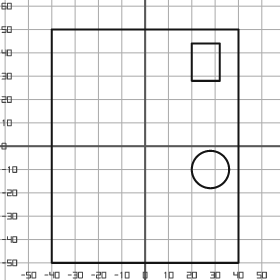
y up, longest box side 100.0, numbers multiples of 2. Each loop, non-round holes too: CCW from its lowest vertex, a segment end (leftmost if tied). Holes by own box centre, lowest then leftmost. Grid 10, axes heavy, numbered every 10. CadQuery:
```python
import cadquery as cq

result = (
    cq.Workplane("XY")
    .moveTo(-40.0, -50.0)
    .lineTo(40.0, -50.0)
    .lineTo(40.0, 50.0)
    .lineTo(-40.0, 50.0)
    .close()
    .moveTo(28.0, -10.0)
    .circle(8.0)
    .moveTo(20.0, 28.0)
    .lineTo(32.0, 28.0)
    .lineTo(32.0, 44.0)
    .lineTo(20.0, 44.0)
    .close()
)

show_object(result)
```